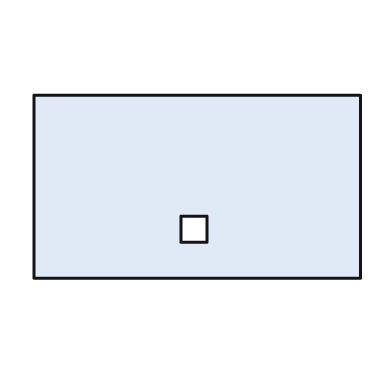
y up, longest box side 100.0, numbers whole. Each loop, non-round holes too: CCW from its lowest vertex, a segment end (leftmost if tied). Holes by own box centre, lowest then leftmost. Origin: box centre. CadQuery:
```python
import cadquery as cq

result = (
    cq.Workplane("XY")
    .moveTo(-50.0, -28.0)
    .lineTo(50.0, -28.0)
    .lineTo(50.0, 28.0)
    .lineTo(-50.0, 28.0)
    .close()
    .moveTo(-5.0, -17.0)
    .lineTo(3.0, -17.0)
    .lineTo(3.0, -9.0)
    .lineTo(-5.0, -9.0)
    .close()
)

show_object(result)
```